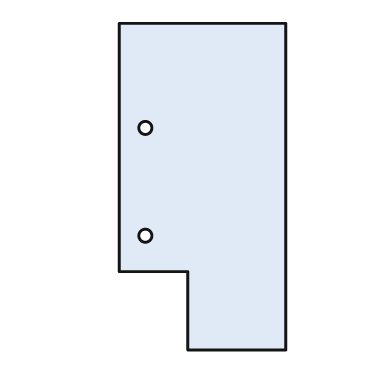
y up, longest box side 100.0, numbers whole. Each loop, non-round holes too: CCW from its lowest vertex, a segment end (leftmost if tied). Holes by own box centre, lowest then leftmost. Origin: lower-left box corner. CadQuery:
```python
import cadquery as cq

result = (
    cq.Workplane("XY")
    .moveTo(21.0, 0.0)
    .lineTo(51.0, 0.0)
    .lineTo(51.0, 100.0)
    .lineTo(0.0, 100.0)
    .lineTo(0.0, 24.0)
    .lineTo(21.0, 24.0)
    .close()
    .moveTo(8.0, 35.0)
    .circle(2.0)
    .moveTo(8.0, 68.0)
    .circle(2.0)
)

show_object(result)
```